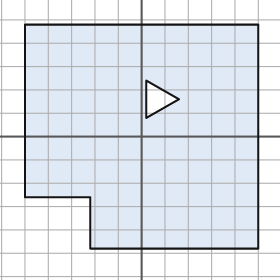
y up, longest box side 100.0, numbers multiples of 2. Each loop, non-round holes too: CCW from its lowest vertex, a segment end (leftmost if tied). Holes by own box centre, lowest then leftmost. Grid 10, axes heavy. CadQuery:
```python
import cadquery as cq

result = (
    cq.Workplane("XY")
    .moveTo(-22.0, -48.0)
    .lineTo(50.0, -48.0)
    .lineTo(50.0, 48.0)
    .lineTo(-50.0, 48.0)
    .lineTo(-50.0, -26.0)
    .lineTo(-22.0, -26.0)
    .close()
    .moveTo(2.0, 8.0)
    .lineTo(16.0, 16.0)
    .lineTo(2.0, 24.0)
    .close()
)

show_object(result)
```